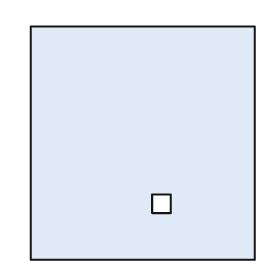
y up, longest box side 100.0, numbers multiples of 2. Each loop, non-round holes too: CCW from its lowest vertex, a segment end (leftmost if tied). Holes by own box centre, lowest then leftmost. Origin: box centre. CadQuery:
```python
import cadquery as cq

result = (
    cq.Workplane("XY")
    .moveTo(-48.0, -50.0)
    .lineTo(48.0, -50.0)
    .lineTo(48.0, 50.0)
    .lineTo(-48.0, 50.0)
    .close()
    .moveTo(4.0, -30.0)
    .lineTo(12.0, -30.0)
    .lineTo(12.0, -22.0)
    .lineTo(4.0, -22.0)
    .close()
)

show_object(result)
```